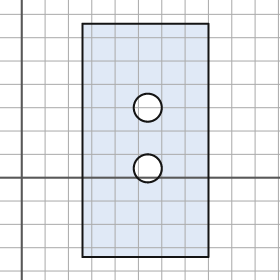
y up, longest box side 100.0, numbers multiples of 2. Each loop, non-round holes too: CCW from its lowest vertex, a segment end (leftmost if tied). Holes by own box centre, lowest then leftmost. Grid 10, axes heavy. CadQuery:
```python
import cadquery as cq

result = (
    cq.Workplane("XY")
    .moveTo(26.0, -34.0)
    .lineTo(80.0, -34.0)
    .lineTo(80.0, 66.0)
    .lineTo(26.0, 66.0)
    .close()
    .moveTo(54.0, 4.0)
    .circle(6.0)
    .moveTo(54.0, 30.0)
    .circle(6.0)
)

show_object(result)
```